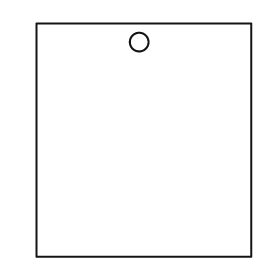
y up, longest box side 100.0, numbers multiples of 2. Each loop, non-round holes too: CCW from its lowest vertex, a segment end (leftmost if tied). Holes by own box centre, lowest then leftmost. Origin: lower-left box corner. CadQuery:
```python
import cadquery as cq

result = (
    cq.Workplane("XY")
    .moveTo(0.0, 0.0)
    .lineTo(92.0, 0.0)
    .lineTo(92.0, 100.0)
    .lineTo(0.0, 100.0)
    .close()
    .moveTo(44.0, 92.0)
    .circle(4.0)
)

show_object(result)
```